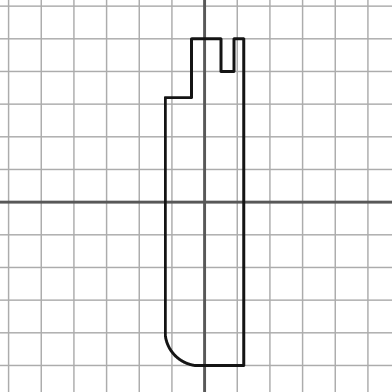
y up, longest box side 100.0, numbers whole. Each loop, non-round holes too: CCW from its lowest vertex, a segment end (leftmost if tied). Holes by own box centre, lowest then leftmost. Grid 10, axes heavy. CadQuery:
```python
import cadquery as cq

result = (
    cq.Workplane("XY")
    .moveTo(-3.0, -50.0)
    .lineTo(12.0, -50.0)
    .lineTo(12.0, 50.0)
    .lineTo(9.0, 50.0)
    .lineTo(9.0, 40.0)
    .lineTo(5.0, 40.0)
    .lineTo(5.0, 50.0)
    .lineTo(-4.0, 50.0)
    .lineTo(-4.0, 32.0)
    .lineTo(-12.0, 32.0)
    .lineTo(-12.0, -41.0)
    .threePointArc((-9.0, -47.0), (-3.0, -50.0))
    .close()
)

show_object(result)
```